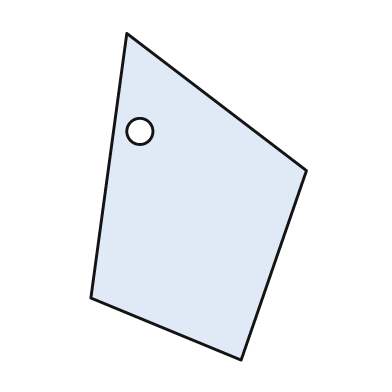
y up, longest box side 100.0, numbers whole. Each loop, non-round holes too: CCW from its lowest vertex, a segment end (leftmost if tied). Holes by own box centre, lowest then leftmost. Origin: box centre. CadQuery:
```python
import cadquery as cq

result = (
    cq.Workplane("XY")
    .moveTo(13.0, -50.0)
    .lineTo(33.0, 8.0)
    .lineTo(-22.0, 50.0)
    .lineTo(-33.0, -31.0)
    .close()
    .moveTo(-18.0, 20.0)
    .circle(4.0)
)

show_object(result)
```